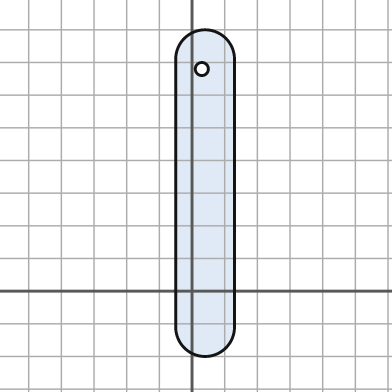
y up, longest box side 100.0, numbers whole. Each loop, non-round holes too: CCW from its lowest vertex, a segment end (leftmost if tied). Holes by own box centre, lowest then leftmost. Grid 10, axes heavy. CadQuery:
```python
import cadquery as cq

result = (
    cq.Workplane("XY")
    .moveTo(-5.0, -11.0)
    .threePointArc((4.0, -20.0), (13.0, -11.0))
    .lineTo(13.0, 71.0)
    .threePointArc((4.0, 80.0), (-5.0, 71.0))
    .close()
    .moveTo(3.0, 68.0)
    .circle(2.0)
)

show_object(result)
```